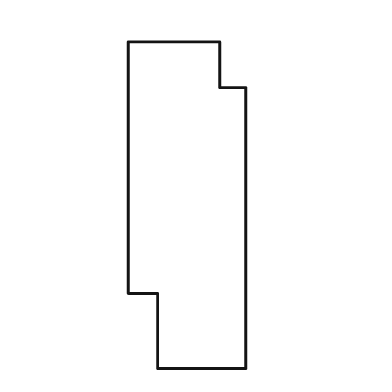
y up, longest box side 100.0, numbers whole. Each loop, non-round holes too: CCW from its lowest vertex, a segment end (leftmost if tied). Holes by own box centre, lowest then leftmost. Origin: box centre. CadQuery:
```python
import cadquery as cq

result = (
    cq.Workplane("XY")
    .moveTo(-9.0, -50.0)
    .lineTo(18.0, -50.0)
    .lineTo(18.0, 36.0)
    .lineTo(10.0, 36.0)
    .lineTo(10.0, 50.0)
    .lineTo(-18.0, 50.0)
    .lineTo(-18.0, -27.0)
    .lineTo(-9.0, -27.0)
    .close()
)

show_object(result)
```